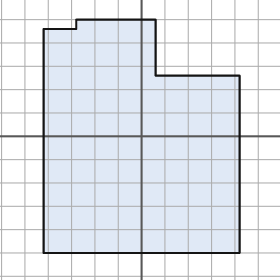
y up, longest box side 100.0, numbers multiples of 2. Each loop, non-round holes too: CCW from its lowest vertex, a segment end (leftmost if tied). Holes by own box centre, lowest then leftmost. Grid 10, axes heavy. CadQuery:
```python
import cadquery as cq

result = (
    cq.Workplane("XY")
    .moveTo(-42.0, -50.0)
    .lineTo(42.0, -50.0)
    .lineTo(42.0, 26.0)
    .lineTo(6.0, 26.0)
    .lineTo(6.0, 50.0)
    .lineTo(-28.0, 50.0)
    .lineTo(-28.0, 46.0)
    .lineTo(-42.0, 46.0)
    .close()
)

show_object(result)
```